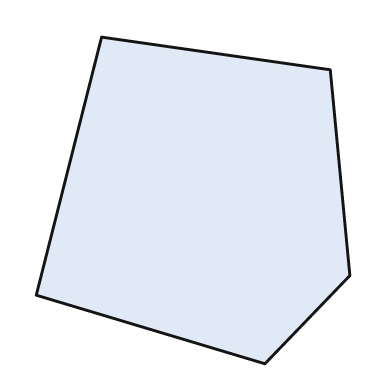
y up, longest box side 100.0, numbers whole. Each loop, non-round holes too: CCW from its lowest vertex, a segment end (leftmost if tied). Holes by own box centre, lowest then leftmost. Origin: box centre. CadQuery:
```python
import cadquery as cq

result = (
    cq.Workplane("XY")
    .moveTo(22.0, -50.0)
    .lineTo(48.0, -23.0)
    .lineTo(42.0, 40.0)
    .lineTo(-28.0, 50.0)
    .lineTo(-48.0, -29.0)
    .close()
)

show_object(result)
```